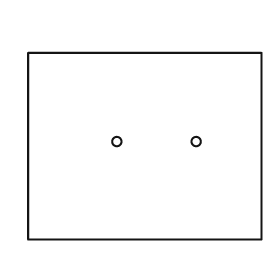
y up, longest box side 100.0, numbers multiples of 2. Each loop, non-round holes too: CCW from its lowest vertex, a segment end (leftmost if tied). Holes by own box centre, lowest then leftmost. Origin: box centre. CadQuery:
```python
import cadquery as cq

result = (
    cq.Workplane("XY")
    .moveTo(-50.0, -40.0)
    .lineTo(50.0, -40.0)
    .lineTo(50.0, 40.0)
    .lineTo(-50.0, 40.0)
    .close()
    .moveTo(-12.0, 2.0)
    .circle(2.0)
    .moveTo(22.0, 2.0)
    .circle(2.0)
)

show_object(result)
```